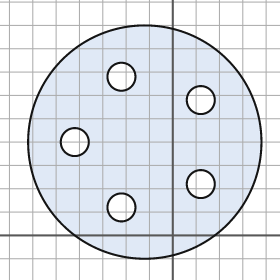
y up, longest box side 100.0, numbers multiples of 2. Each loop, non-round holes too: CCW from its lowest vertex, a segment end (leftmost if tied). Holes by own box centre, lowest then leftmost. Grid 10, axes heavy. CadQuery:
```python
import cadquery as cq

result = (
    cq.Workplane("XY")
    .moveTo(-12.0, 40.0)
    .circle(50.0)
    .moveTo(-22.0, 12.0)
    .circle(6.0)
    .moveTo(12.0, 22.0)
    .circle(6.0)
    .moveTo(-42.0, 40.0)
    .circle(6.0)
    .moveTo(12.0, 58.0)
    .circle(6.0)
    .moveTo(-22.0, 68.0)
    .circle(6.0)
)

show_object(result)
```